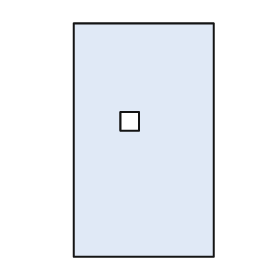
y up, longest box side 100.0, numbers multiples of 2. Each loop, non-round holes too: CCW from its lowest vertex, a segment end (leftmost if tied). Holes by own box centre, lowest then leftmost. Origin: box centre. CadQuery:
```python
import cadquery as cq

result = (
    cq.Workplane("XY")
    .moveTo(-30.0, -50.0)
    .lineTo(30.0, -50.0)
    .lineTo(30.0, 50.0)
    .lineTo(-30.0, 50.0)
    .close()
    .moveTo(-10.0, 4.0)
    .lineTo(-2.0, 4.0)
    .lineTo(-2.0, 12.0)
    .lineTo(-10.0, 12.0)
    .close()
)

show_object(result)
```